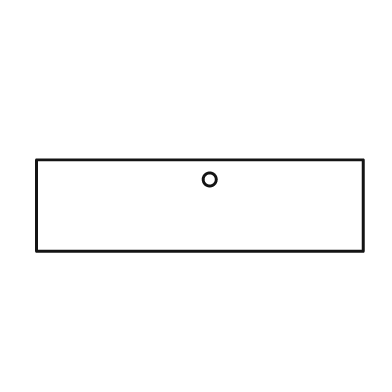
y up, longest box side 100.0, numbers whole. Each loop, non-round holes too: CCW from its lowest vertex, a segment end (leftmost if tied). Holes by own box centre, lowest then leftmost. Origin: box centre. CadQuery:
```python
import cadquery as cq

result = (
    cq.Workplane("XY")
    .moveTo(-50.0, -14.0)
    .lineTo(50.0, -14.0)
    .lineTo(50.0, 14.0)
    .lineTo(-50.0, 14.0)
    .close()
    .moveTo(3.0, 8.0)
    .circle(2.0)
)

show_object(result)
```